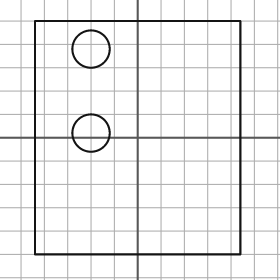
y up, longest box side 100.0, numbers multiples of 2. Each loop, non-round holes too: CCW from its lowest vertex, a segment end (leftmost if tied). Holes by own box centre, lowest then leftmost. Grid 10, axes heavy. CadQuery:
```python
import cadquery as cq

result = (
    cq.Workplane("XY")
    .moveTo(-44.0, -50.0)
    .lineTo(44.0, -50.0)
    .lineTo(44.0, 50.0)
    .lineTo(-44.0, 50.0)
    .close()
    .moveTo(-20.0, 2.0)
    .circle(8.0)
    .moveTo(-20.0, 38.0)
    .circle(8.0)
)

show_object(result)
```